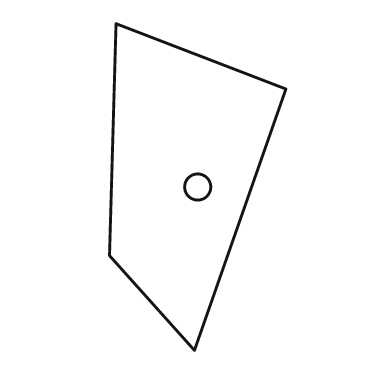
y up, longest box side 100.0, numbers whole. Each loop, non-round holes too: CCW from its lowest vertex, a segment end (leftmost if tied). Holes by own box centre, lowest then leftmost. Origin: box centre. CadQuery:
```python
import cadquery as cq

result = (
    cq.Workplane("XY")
    .moveTo(-1.0, -50.0)
    .lineTo(27.0, 30.0)
    .lineTo(-25.0, 50.0)
    .lineTo(-27.0, -21.0)
    .close()
    .moveTo(0.0, 0.0)
    .circle(4.0)
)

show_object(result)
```